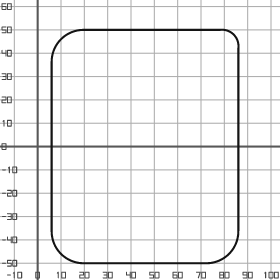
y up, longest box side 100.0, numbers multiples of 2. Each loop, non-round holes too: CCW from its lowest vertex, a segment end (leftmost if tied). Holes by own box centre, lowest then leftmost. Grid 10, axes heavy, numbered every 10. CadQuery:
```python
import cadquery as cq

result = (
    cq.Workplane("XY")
    .moveTo(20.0, -50.0)
    .lineTo(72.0, -50.0)
    .threePointArc((82.0, -46.0), (86.0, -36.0))
    .lineTo(86.0, 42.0)
    .threePointArc((84.0, 48.0), (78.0, 50.0))
    .lineTo(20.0, 50.0)
    .threePointArc((10.0, 46.0), (6.0, 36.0))
    .lineTo(6.0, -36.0)
    .threePointArc((10.0, -46.0), (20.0, -50.0))
    .close()
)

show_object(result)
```